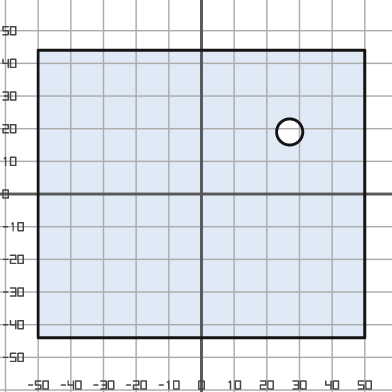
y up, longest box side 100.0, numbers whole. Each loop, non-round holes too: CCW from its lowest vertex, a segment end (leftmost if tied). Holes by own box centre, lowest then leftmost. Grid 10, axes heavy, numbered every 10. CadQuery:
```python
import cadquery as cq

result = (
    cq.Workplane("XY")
    .moveTo(-50.0, -44.0)
    .lineTo(50.0, -44.0)
    .lineTo(50.0, 44.0)
    .lineTo(-50.0, 44.0)
    .close()
    .moveTo(27.0, 19.0)
    .circle(4.0)
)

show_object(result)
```